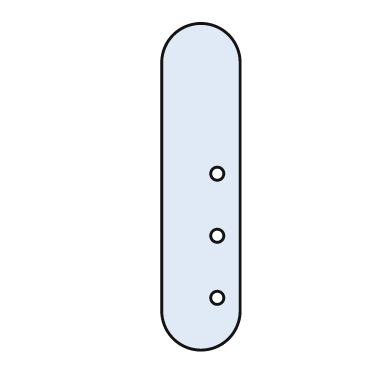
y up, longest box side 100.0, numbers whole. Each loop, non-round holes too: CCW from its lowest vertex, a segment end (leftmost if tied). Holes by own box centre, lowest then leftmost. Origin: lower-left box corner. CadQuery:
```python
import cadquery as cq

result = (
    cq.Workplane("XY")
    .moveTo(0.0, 12.0)
    .threePointArc((12.0, 0.0), (24.0, 12.0))
    .lineTo(24.0, 88.0)
    .threePointArc((12.0, 100.0), (0.0, 88.0))
    .close()
    .moveTo(17.0, 16.0)
    .circle(2.0)
    .moveTo(17.0, 35.0)
    .circle(2.0)
    .moveTo(17.0, 54.0)
    .circle(2.0)
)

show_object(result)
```